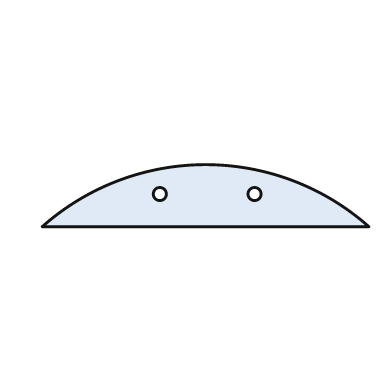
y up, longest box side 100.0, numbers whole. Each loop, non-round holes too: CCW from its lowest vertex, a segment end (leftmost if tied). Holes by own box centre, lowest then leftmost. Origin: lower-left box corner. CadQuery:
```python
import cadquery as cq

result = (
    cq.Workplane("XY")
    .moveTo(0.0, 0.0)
    .lineTo(100.0, 0.0)
    .threePointArc((50.0, 19.0), (0.0, 0.0))
    .close()
    .moveTo(36.0, 10.0)
    .circle(2.0)
    .moveTo(65.0, 10.0)
    .circle(2.0)
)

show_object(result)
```